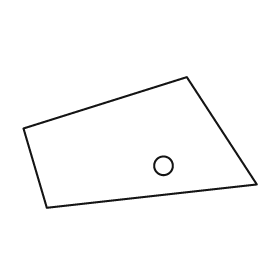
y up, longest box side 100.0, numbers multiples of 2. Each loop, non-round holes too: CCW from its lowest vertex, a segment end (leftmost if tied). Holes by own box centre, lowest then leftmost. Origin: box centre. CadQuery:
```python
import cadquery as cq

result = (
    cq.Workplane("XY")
    .moveTo(-40.0, -28.0)
    .lineTo(50.0, -18.0)
    .lineTo(20.0, 28.0)
    .lineTo(-50.0, 6.0)
    .close()
    .moveTo(10.0, -10.0)
    .circle(4.0)
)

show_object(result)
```